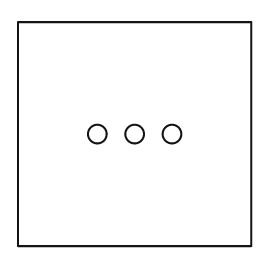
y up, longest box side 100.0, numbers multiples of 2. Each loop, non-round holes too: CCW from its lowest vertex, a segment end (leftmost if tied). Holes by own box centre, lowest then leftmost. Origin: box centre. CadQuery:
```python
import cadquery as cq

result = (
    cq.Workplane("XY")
    .moveTo(-50.0, -48.0)
    .lineTo(50.0, -48.0)
    .lineTo(50.0, 48.0)
    .lineTo(-50.0, 48.0)
    .close()
    .moveTo(-16.0, 0.0)
    .circle(4.0)
    .moveTo(0.0, 0.0)
    .circle(4.0)
    .moveTo(16.0, 0.0)
    .circle(4.0)
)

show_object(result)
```